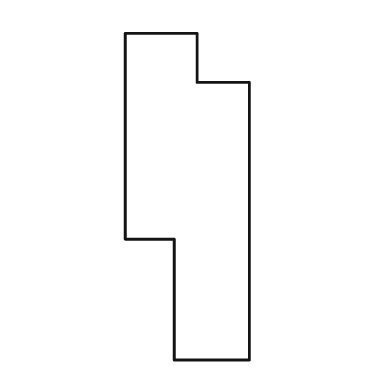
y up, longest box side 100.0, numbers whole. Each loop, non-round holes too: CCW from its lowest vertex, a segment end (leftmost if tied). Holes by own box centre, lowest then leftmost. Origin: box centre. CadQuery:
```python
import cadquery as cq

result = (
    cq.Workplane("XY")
    .moveTo(-4.0, -50.0)
    .lineTo(19.0, -50.0)
    .lineTo(19.0, 35.0)
    .lineTo(3.0, 35.0)
    .lineTo(3.0, 50.0)
    .lineTo(-19.0, 50.0)
    .lineTo(-19.0, -13.0)
    .lineTo(-4.0, -13.0)
    .close()
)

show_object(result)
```